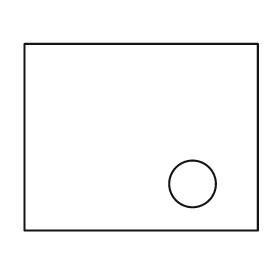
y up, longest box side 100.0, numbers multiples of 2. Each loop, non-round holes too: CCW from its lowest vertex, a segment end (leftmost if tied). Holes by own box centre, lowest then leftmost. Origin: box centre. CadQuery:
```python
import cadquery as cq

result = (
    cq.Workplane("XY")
    .moveTo(-50.0, -40.0)
    .lineTo(50.0, -40.0)
    .lineTo(50.0, 40.0)
    .lineTo(-50.0, 40.0)
    .close()
    .moveTo(22.0, -20.0)
    .circle(10.0)
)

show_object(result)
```